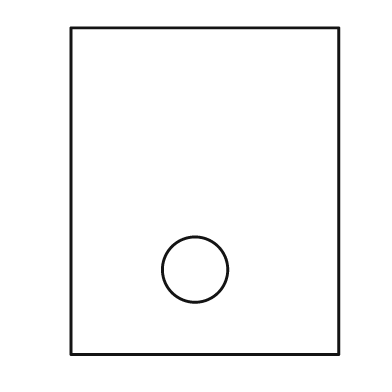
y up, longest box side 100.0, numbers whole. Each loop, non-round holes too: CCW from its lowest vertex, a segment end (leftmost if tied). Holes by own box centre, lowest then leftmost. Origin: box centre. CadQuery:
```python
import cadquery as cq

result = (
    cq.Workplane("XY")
    .moveTo(-41.0, -50.0)
    .lineTo(41.0, -50.0)
    .lineTo(41.0, 50.0)
    .lineTo(-41.0, 50.0)
    .close()
    .moveTo(-3.0, -24.0)
    .circle(10.0)
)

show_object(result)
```